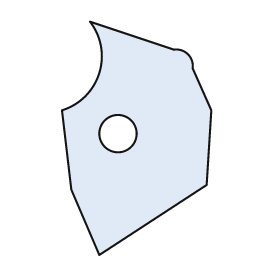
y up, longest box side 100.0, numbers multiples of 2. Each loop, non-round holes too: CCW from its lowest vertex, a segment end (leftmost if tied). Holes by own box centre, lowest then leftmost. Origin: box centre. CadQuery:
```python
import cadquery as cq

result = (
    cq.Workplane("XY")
    .moveTo(-16.0, -50.0)
    .lineTo(30.0, -20.0)
    .lineTo(32.0, 12.0)
    .lineTo(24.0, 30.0)
    .threePointArc((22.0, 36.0), (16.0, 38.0))
    .lineTo(-20.0, 50.0)
    .threePointArc((-16.0, 28.0), (-32.0, 12.0))
    .lineTo(-28.0, -22.0)
    .close()
    .moveTo(-8.0, 2.0)
    .circle(8.0)
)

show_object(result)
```